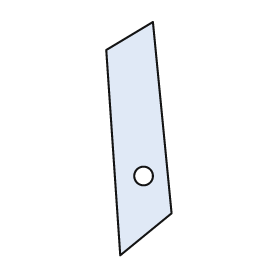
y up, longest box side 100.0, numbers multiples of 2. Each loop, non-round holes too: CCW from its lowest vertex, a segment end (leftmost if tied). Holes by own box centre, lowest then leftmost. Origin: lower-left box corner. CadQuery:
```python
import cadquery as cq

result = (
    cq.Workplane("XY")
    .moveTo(6.0, 0.0)
    .lineTo(28.0, 18.0)
    .lineTo(20.0, 100.0)
    .lineTo(0.0, 88.0)
    .close()
    .moveTo(16.0, 34.0)
    .circle(4.0)
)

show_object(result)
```